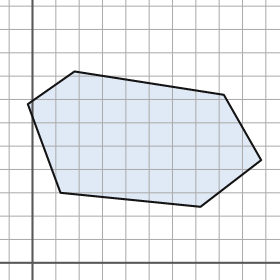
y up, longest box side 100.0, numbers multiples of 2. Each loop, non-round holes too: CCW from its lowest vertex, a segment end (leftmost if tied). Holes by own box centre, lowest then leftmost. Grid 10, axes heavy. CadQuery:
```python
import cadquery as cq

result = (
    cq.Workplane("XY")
    .moveTo(72.0, 24.0)
    .lineTo(98.0, 44.0)
    .lineTo(82.0, 72.0)
    .lineTo(18.0, 82.0)
    .lineTo(-2.0, 68.0)
    .lineTo(12.0, 30.0)
    .close()
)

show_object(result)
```